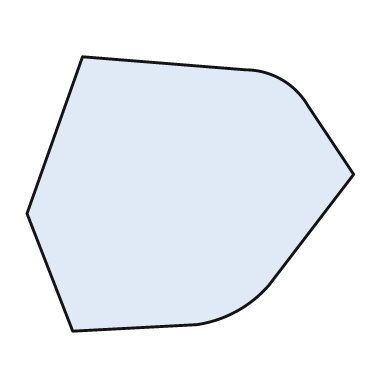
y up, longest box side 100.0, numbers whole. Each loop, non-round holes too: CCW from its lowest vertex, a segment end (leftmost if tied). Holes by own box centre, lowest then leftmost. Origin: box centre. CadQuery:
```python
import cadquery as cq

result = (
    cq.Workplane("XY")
    .moveTo(-36.0, -42.0)
    .lineTo(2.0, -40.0)
    .threePointArc((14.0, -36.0), (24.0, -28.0))
    .lineTo(50.0, 6.0)
    .lineTo(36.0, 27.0)
    .threePointArc((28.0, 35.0), (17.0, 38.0))
    .lineTo(-33.0, 42.0)
    .lineTo(-50.0, -6.0)
    .close()
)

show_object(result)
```